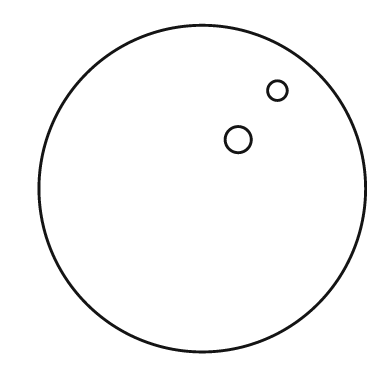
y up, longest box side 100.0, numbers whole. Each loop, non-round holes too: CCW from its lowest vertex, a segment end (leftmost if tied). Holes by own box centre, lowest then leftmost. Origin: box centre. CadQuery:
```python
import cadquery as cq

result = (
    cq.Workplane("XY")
    .moveTo(0.0, 0.0)
    .circle(50.0)
    .moveTo(11.0, 15.0)
    .circle(4.0)
    .moveTo(23.0, 30.0)
    .circle(3.0)
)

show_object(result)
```